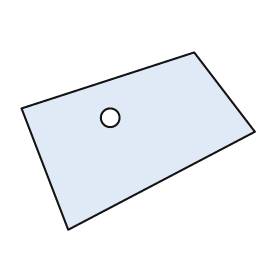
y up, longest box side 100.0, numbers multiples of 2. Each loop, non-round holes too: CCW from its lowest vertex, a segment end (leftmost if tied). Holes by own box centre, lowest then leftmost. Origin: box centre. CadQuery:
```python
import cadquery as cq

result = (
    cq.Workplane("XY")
    .moveTo(-30.0, -38.0)
    .lineTo(50.0, 4.0)
    .lineTo(24.0, 38.0)
    .lineTo(-50.0, 14.0)
    .close()
    .moveTo(-12.0, 10.0)
    .circle(4.0)
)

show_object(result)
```